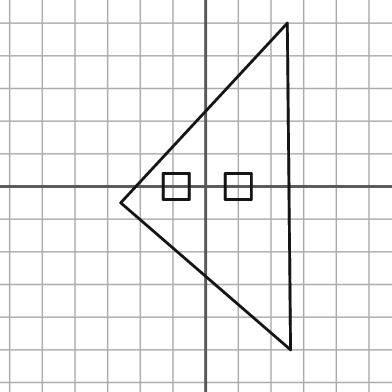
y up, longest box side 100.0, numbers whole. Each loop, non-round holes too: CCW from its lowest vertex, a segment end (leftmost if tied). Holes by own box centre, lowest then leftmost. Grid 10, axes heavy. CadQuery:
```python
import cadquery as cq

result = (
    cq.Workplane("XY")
    .moveTo(26.0, -50.0)
    .lineTo(25.0, 50.0)
    .lineTo(-26.0, -5.0)
    .close()
    .moveTo(-13.0, -4.0)
    .lineTo(-5.0, -4.0)
    .lineTo(-5.0, 4.0)
    .lineTo(-13.0, 4.0)
    .close()
    .moveTo(6.0, -4.0)
    .lineTo(14.0, -4.0)
    .lineTo(14.0, 4.0)
    .lineTo(6.0, 4.0)
    .close()
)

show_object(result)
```